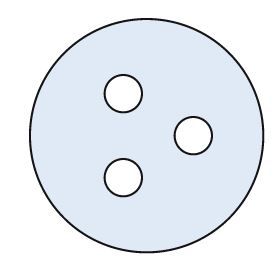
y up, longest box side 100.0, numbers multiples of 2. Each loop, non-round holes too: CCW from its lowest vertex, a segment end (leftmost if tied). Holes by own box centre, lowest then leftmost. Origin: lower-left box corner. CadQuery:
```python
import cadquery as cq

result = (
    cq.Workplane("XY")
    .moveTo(50.0, 50.0)
    .circle(50.0)
    .moveTo(40.0, 32.0)
    .circle(8.0)
    .moveTo(70.0, 50.0)
    .circle(8.0)
    .moveTo(40.0, 68.0)
    .circle(8.0)
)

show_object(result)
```